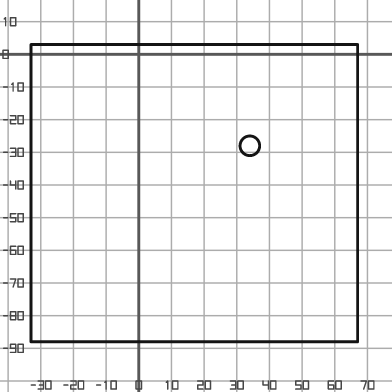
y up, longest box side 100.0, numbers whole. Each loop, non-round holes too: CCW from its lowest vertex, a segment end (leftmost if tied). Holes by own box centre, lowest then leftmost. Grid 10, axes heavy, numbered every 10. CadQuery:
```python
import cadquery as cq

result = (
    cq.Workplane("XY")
    .moveTo(-33.0, -88.0)
    .lineTo(67.0, -88.0)
    .lineTo(67.0, 3.0)
    .lineTo(-33.0, 3.0)
    .close()
    .moveTo(34.0, -28.0)
    .circle(3.0)
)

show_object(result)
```